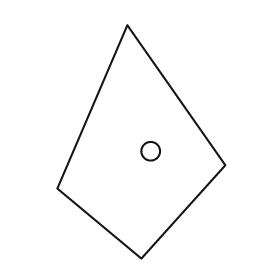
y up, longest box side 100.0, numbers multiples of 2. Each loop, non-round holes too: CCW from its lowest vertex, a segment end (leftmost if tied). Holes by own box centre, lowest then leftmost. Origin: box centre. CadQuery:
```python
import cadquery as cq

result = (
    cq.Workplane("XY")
    .moveTo(0.0, -50.0)
    .lineTo(36.0, -10.0)
    .lineTo(-6.0, 50.0)
    .lineTo(-36.0, -20.0)
    .close()
    .moveTo(4.0, -4.0)
    .circle(4.0)
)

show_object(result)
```